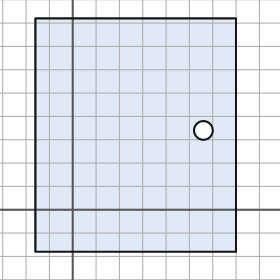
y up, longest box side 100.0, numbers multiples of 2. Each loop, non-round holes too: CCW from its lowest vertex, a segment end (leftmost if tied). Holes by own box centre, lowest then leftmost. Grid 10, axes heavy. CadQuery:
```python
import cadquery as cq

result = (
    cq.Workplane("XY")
    .moveTo(-16.0, -18.0)
    .lineTo(70.0, -18.0)
    .lineTo(70.0, 82.0)
    .lineTo(-16.0, 82.0)
    .close()
    .moveTo(56.0, 34.0)
    .circle(4.0)
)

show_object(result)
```